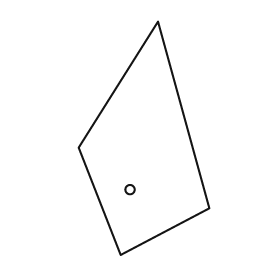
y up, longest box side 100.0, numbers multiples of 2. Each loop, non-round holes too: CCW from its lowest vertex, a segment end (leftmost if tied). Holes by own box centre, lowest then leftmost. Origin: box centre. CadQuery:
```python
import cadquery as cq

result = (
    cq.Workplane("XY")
    .moveTo(-10.0, -50.0)
    .lineTo(28.0, -30.0)
    .lineTo(6.0, 50.0)
    .lineTo(-28.0, -4.0)
    .close()
    .moveTo(-6.0, -22.0)
    .circle(2.0)
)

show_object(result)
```